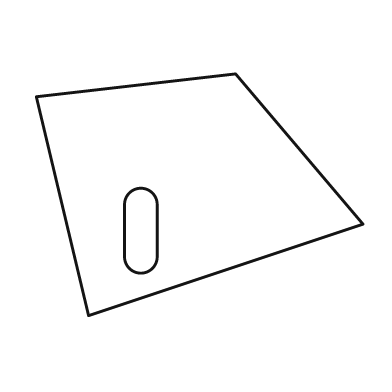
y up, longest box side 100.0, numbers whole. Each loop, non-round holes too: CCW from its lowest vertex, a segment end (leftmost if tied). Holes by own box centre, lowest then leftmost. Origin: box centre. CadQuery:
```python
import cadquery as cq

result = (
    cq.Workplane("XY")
    .moveTo(-34.0, -37.0)
    .lineTo(50.0, -9.0)
    .lineTo(11.0, 37.0)
    .lineTo(-50.0, 30.0)
    .close()
    .moveTo(-23.0, -19.0)
    .threePointArc((-18.0, -24.0), (-13.0, -19.0))
    .lineTo(-13.0, -3.0)
    .threePointArc((-18.0, 2.0), (-23.0, -3.0))
    .close()
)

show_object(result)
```